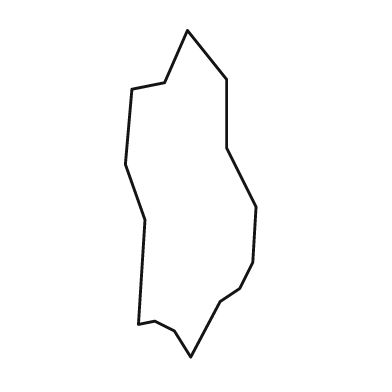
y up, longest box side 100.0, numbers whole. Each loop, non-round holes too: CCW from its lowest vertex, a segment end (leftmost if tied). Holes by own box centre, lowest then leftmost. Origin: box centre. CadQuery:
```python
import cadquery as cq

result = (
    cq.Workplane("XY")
    .moveTo(0.0, -50.0)
    .lineTo(9.0, -33.0)
    .lineTo(15.0, -29.0)
    .lineTo(19.0, -21.0)
    .lineTo(20.0, -4.0)
    .lineTo(11.0, 14.0)
    .lineTo(11.0, 35.0)
    .lineTo(-1.0, 50.0)
    .lineTo(-8.0, 34.0)
    .lineTo(-18.0, 32.0)
    .lineTo(-20.0, 9.0)
    .lineTo(-14.0, -8.0)
    .lineTo(-16.0, -40.0)
    .lineTo(-11.0, -39.0)
    .lineTo(-5.0, -42.0)
    .close()
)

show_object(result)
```